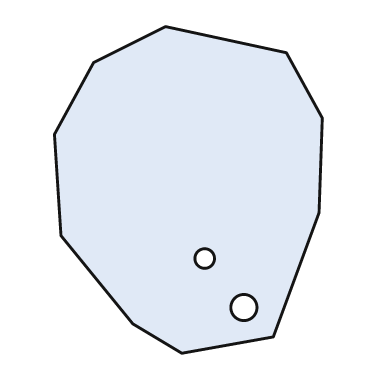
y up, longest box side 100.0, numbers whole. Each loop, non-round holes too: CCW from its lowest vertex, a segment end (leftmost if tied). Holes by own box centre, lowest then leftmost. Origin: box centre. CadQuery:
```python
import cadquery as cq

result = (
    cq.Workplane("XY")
    .moveTo(-2.0, -50.0)
    .lineTo(26.0, -45.0)
    .lineTo(40.0, -7.0)
    .lineTo(41.0, 22.0)
    .lineTo(30.0, 42.0)
    .lineTo(-7.0, 50.0)
    .lineTo(-29.0, 39.0)
    .lineTo(-41.0, 17.0)
    .lineTo(-39.0, -14.0)
    .lineTo(-17.0, -41.0)
    .close()
    .moveTo(17.0, -36.0)
    .circle(4.0)
    .moveTo(5.0, -21.0)
    .circle(3.0)
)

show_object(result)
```